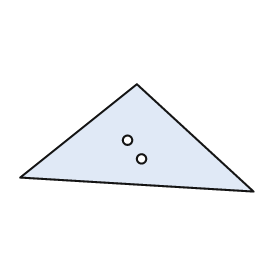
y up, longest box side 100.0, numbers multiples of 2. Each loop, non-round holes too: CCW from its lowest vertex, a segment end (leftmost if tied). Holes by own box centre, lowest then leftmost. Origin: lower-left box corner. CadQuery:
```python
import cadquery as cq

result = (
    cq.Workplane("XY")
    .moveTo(100.0, 0.0)
    .lineTo(50.0, 46.0)
    .lineTo(0.0, 6.0)
    .close()
    .moveTo(52.0, 14.0)
    .circle(2.0)
    .moveTo(46.0, 22.0)
    .circle(2.0)
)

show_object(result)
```